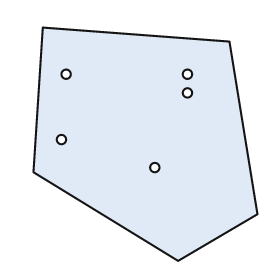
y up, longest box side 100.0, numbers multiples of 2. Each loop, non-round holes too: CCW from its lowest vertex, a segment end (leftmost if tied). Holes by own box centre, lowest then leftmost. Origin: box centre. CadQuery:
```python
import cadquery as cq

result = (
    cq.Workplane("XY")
    .moveTo(14.0, -50.0)
    .lineTo(48.0, -30.0)
    .lineTo(36.0, 44.0)
    .lineTo(-44.0, 50.0)
    .lineTo(-48.0, -12.0)
    .close()
    .moveTo(4.0, -10.0)
    .circle(2.0)
    .moveTo(-36.0, 2.0)
    .circle(2.0)
    .moveTo(18.0, 22.0)
    .circle(2.0)
    .moveTo(-34.0, 30.0)
    .circle(2.0)
    .moveTo(18.0, 30.0)
    .circle(2.0)
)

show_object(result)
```